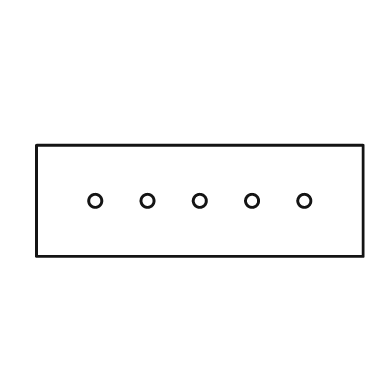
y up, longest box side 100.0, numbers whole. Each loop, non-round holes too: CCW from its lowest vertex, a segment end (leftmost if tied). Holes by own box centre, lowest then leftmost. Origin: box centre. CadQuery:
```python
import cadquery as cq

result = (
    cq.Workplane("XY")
    .moveTo(-50.0, -17.0)
    .lineTo(50.0, -17.0)
    .lineTo(50.0, 17.0)
    .lineTo(-50.0, 17.0)
    .close()
    .moveTo(-32.0, 0.0)
    .circle(2.0)
    .moveTo(-16.0, 0.0)
    .circle(2.0)
    .moveTo(0.0, 0.0)
    .circle(2.0)
    .moveTo(16.0, 0.0)
    .circle(2.0)
    .moveTo(32.0, 0.0)
    .circle(2.0)
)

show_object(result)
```